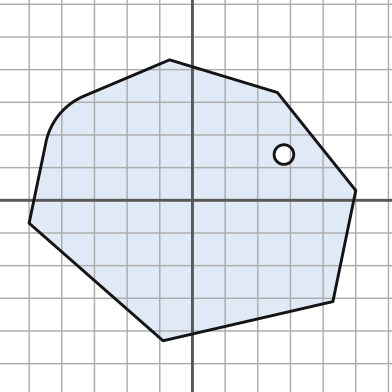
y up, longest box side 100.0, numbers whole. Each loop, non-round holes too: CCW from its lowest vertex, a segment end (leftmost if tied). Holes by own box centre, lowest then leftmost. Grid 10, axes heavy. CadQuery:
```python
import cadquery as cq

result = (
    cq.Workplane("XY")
    .moveTo(-9.0, -43.0)
    .lineTo(43.0, -31.0)
    .lineTo(50.0, 3.0)
    .lineTo(26.0, 33.0)
    .lineTo(-7.0, 43.0)
    .lineTo(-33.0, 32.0)
    .threePointArc((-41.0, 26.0), (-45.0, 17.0))
    .lineTo(-50.0, -7.0)
    .close()
    .moveTo(28.0, 14.0)
    .circle(3.0)
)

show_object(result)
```